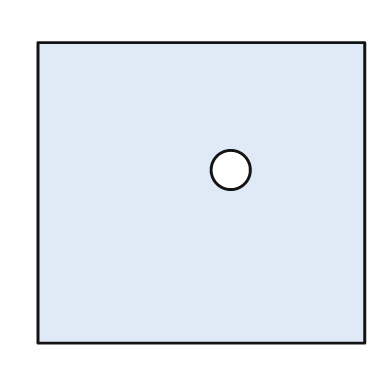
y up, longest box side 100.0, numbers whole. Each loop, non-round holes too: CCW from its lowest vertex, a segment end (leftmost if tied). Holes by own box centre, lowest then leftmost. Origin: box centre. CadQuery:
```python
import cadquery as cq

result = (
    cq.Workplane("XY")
    .moveTo(-50.0, -46.0)
    .lineTo(50.0, -46.0)
    .lineTo(50.0, 46.0)
    .lineTo(-50.0, 46.0)
    .close()
    .moveTo(9.0, 7.0)
    .circle(6.0)
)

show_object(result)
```